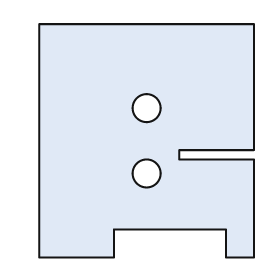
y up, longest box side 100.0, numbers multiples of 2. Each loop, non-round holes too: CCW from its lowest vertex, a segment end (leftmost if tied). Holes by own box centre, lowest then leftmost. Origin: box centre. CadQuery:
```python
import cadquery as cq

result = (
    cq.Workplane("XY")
    .moveTo(-46.0, -50.0)
    .lineTo(-14.0, -50.0)
    .lineTo(-14.0, -38.0)
    .lineTo(34.0, -38.0)
    .lineTo(34.0, -50.0)
    .lineTo(46.0, -50.0)
    .lineTo(46.0, -8.0)
    .lineTo(14.0, -8.0)
    .lineTo(14.0, -4.0)
    .lineTo(46.0, -4.0)
    .lineTo(46.0, 50.0)
    .lineTo(-46.0, 50.0)
    .close()
    .moveTo(0.0, -14.0)
    .circle(6.0)
    .moveTo(0.0, 14.0)
    .circle(6.0)
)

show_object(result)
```